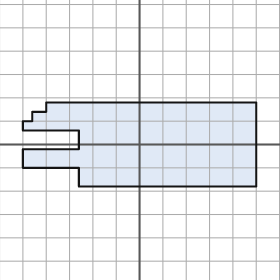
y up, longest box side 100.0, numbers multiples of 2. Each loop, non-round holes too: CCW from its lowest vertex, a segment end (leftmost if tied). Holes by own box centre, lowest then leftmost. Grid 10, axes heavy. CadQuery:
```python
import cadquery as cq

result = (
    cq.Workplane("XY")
    .moveTo(-26.0, -18.0)
    .lineTo(50.0, -18.0)
    .lineTo(50.0, 18.0)
    .lineTo(-40.0, 18.0)
    .lineTo(-40.0, 14.0)
    .lineTo(-46.0, 14.0)
    .lineTo(-46.0, 10.0)
    .lineTo(-50.0, 10.0)
    .lineTo(-50.0, 6.0)
    .lineTo(-26.0, 6.0)
    .lineTo(-26.0, -2.0)
    .lineTo(-50.0, -2.0)
    .lineTo(-50.0, -10.0)
    .lineTo(-26.0, -10.0)
    .close()
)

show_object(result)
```